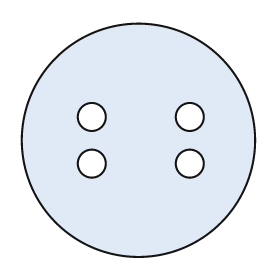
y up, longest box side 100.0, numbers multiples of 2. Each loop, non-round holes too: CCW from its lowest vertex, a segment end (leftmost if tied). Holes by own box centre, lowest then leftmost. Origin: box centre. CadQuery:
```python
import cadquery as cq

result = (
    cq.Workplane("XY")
    .moveTo(0.0, 0.0)
    .circle(50.0)
    .moveTo(-20.0, -10.0)
    .circle(6.0)
    .moveTo(22.0, -10.0)
    .circle(6.0)
    .moveTo(-20.0, 10.0)
    .circle(6.0)
    .moveTo(22.0, 10.0)
    .circle(6.0)
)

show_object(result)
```